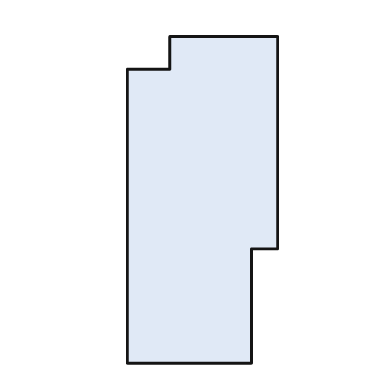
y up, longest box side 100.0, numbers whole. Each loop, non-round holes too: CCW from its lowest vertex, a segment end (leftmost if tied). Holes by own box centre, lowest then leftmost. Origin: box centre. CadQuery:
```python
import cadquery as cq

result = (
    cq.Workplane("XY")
    .moveTo(-23.0, -50.0)
    .lineTo(15.0, -50.0)
    .lineTo(15.0, -15.0)
    .lineTo(23.0, -15.0)
    .lineTo(23.0, 50.0)
    .lineTo(-10.0, 50.0)
    .lineTo(-10.0, 40.0)
    .lineTo(-23.0, 40.0)
    .close()
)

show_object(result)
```